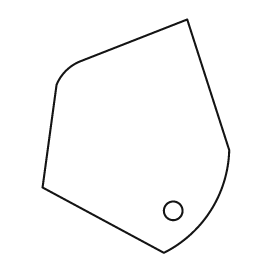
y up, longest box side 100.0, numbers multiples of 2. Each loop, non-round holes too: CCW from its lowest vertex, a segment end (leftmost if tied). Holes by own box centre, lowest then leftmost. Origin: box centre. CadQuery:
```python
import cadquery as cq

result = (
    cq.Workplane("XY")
    .moveTo(12.0, -50.0)
    .threePointArc((32.0, -32.0), (40.0, -6.0))
    .lineTo(22.0, 50.0)
    .lineTo(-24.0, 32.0)
    .threePointArc((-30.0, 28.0), (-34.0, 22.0))
    .lineTo(-40.0, -22.0)
    .close()
    .moveTo(16.0, -32.0)
    .circle(4.0)
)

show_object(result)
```